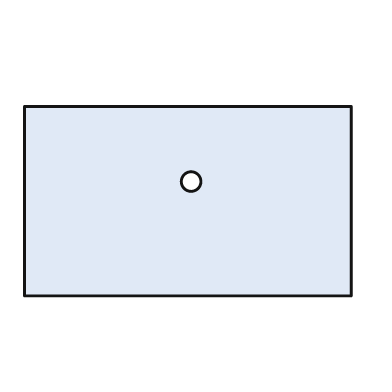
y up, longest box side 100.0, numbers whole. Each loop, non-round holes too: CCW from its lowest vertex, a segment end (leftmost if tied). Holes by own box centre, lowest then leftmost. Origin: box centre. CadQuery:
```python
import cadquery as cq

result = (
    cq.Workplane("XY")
    .moveTo(-50.0, -29.0)
    .lineTo(50.0, -29.0)
    .lineTo(50.0, 29.0)
    .lineTo(-50.0, 29.0)
    .close()
    .moveTo(1.0, 6.0)
    .circle(3.0)
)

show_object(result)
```